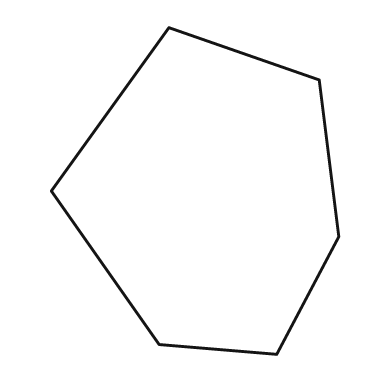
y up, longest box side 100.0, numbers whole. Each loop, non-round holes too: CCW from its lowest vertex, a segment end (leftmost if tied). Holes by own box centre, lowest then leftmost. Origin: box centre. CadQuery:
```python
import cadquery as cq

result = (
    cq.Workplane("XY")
    .moveTo(25.0, -50.0)
    .lineTo(44.0, -14.0)
    .lineTo(38.0, 34.0)
    .lineTo(-8.0, 50.0)
    .lineTo(-44.0, 0.0)
    .lineTo(-11.0, -47.0)
    .close()
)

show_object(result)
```